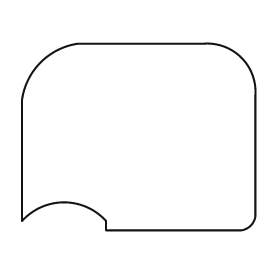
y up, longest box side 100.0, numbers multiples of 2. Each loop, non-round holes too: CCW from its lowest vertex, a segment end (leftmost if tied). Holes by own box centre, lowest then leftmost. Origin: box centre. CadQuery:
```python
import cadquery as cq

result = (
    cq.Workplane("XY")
    .moveTo(-14.0, -40.0)
    .lineTo(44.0, -40.0)
    .threePointArc((48.0, -38.0), (50.0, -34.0))
    .lineTo(50.0, 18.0)
    .threePointArc((44.0, 34.0), (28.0, 40.0))
    .lineTo(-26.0, 40.0)
    .threePointArc((-42.0, 32.0), (-50.0, 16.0))
    .lineTo(-50.0, -36.0)
    .threePointArc((-32.0, -28.0), (-14.0, -36.0))
    .close()
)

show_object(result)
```